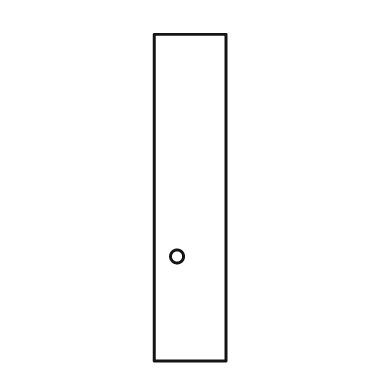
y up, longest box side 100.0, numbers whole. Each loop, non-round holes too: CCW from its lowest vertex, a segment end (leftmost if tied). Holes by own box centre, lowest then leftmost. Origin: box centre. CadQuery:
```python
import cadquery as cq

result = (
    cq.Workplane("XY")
    .moveTo(-11.0, -50.0)
    .lineTo(11.0, -50.0)
    .lineTo(11.0, 50.0)
    .lineTo(-11.0, 50.0)
    .close()
    .moveTo(-4.0, -18.0)
    .circle(2.0)
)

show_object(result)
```